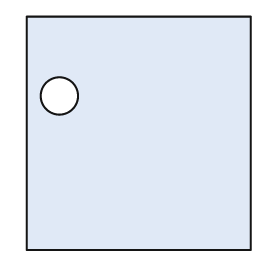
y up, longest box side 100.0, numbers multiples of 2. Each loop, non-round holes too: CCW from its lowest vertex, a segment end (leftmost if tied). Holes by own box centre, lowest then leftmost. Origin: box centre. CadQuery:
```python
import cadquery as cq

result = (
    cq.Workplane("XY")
    .moveTo(-48.0, -50.0)
    .lineTo(48.0, -50.0)
    .lineTo(48.0, 50.0)
    .lineTo(-48.0, 50.0)
    .close()
    .moveTo(-34.0, 16.0)
    .circle(8.0)
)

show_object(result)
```